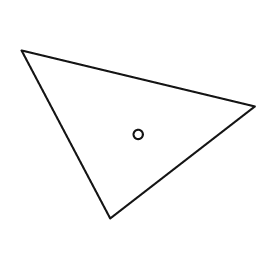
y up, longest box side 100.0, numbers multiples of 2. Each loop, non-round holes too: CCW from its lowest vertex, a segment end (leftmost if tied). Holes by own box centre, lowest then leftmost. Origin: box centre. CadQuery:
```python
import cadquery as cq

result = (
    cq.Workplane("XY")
    .moveTo(-12.0, -36.0)
    .lineTo(50.0, 12.0)
    .lineTo(-50.0, 36.0)
    .close()
    .moveTo(0.0, 0.0)
    .circle(2.0)
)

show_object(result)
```